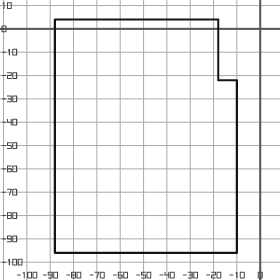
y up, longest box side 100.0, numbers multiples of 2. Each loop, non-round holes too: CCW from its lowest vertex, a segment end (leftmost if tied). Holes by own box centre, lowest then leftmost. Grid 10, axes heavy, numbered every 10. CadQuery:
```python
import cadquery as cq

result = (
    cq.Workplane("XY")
    .moveTo(-88.0, -96.0)
    .lineTo(-10.0, -96.0)
    .lineTo(-10.0, -22.0)
    .lineTo(-18.0, -22.0)
    .lineTo(-18.0, 4.0)
    .lineTo(-88.0, 4.0)
    .close()
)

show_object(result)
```